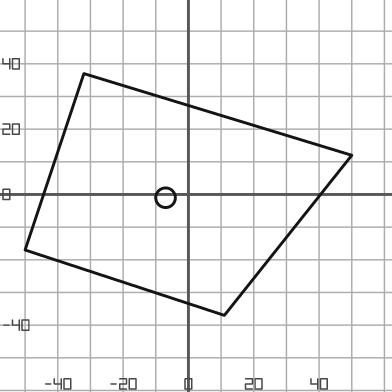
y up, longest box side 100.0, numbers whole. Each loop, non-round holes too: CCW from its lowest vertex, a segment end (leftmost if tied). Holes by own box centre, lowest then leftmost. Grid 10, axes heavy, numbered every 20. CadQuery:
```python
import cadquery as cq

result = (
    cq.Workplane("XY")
    .moveTo(11.0, -37.0)
    .lineTo(50.0, 12.0)
    .lineTo(-32.0, 37.0)
    .lineTo(-50.0, -17.0)
    .close()
    .moveTo(-7.0, -1.0)
    .circle(3.0)
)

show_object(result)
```